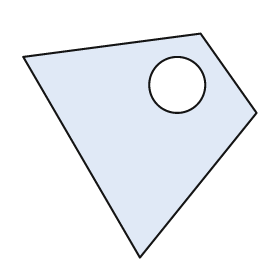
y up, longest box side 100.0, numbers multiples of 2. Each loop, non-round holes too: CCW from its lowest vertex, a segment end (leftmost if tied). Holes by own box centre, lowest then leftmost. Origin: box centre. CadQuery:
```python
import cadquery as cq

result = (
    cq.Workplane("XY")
    .moveTo(0.0, -48.0)
    .lineTo(50.0, 14.0)
    .lineTo(26.0, 48.0)
    .lineTo(-50.0, 38.0)
    .close()
    .moveTo(16.0, 26.0)
    .circle(12.0)
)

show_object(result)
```